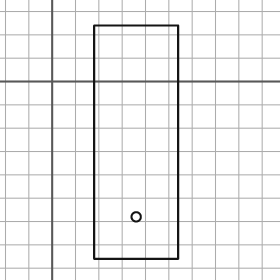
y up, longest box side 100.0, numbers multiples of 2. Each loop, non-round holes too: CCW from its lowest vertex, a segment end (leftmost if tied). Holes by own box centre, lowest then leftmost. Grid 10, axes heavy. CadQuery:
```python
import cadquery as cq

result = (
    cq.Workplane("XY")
    .moveTo(18.0, -76.0)
    .lineTo(54.0, -76.0)
    .lineTo(54.0, 24.0)
    .lineTo(18.0, 24.0)
    .close()
    .moveTo(36.0, -58.0)
    .circle(2.0)
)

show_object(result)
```